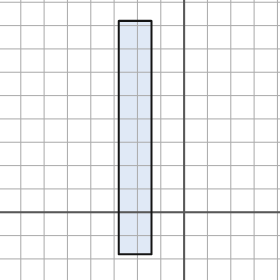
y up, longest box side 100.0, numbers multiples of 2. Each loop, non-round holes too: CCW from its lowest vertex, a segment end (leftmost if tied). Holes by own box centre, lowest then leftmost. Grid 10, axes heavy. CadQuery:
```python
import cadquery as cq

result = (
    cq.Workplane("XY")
    .moveTo(-28.0, -18.0)
    .lineTo(-14.0, -18.0)
    .lineTo(-14.0, 82.0)
    .lineTo(-28.0, 82.0)
    .close()
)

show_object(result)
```